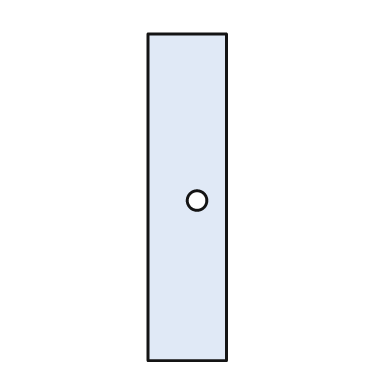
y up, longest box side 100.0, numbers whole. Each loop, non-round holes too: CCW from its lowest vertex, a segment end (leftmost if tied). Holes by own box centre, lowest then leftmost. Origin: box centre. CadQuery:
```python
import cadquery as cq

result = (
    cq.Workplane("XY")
    .moveTo(-12.0, -50.0)
    .lineTo(12.0, -50.0)
    .lineTo(12.0, 50.0)
    .lineTo(-12.0, 50.0)
    .close()
    .moveTo(3.0, -1.0)
    .circle(3.0)
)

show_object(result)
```